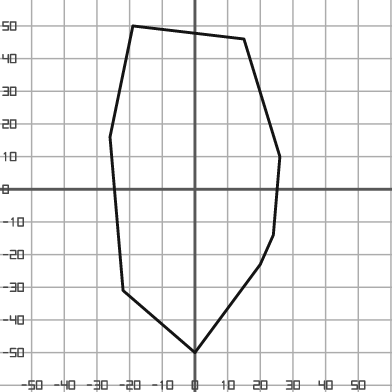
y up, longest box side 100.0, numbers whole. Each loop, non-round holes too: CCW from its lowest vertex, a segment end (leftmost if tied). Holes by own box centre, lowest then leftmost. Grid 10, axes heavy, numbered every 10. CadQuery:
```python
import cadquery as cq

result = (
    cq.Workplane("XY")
    .moveTo(0.0, -50.0)
    .lineTo(20.0, -23.0)
    .lineTo(24.0, -14.0)
    .lineTo(26.0, 10.0)
    .lineTo(15.0, 46.0)
    .lineTo(-19.0, 50.0)
    .lineTo(-26.0, 16.0)
    .lineTo(-22.0, -31.0)
    .close()
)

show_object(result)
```